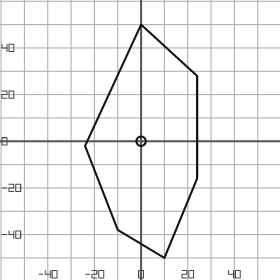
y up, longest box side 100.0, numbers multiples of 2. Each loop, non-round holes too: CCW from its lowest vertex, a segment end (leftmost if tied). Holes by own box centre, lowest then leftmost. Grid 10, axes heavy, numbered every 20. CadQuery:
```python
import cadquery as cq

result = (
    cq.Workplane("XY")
    .moveTo(10.0, -50.0)
    .lineTo(24.0, -16.0)
    .lineTo(24.0, 28.0)
    .lineTo(0.0, 50.0)
    .lineTo(-24.0, -2.0)
    .lineTo(-10.0, -38.0)
    .close()
    .moveTo(0.0, 0.0)
    .circle(2.0)
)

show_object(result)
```